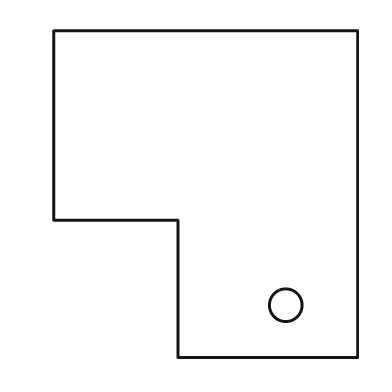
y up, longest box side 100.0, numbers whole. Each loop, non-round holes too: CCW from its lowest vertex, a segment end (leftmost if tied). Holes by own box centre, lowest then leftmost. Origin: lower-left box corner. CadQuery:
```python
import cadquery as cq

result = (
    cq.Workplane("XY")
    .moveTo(38.0, 0.0)
    .lineTo(93.0, 0.0)
    .lineTo(93.0, 100.0)
    .lineTo(0.0, 100.0)
    .lineTo(0.0, 42.0)
    .lineTo(38.0, 42.0)
    .close()
    .moveTo(71.0, 16.0)
    .circle(5.0)
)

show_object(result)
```